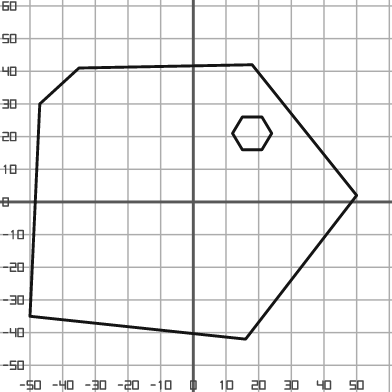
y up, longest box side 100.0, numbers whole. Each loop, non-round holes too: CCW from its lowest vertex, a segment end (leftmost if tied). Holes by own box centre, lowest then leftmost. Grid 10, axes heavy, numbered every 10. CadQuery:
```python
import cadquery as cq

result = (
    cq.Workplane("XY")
    .moveTo(16.0, -42.0)
    .lineTo(50.0, 2.0)
    .lineTo(18.0, 42.0)
    .lineTo(-35.0, 41.0)
    .lineTo(-47.0, 30.0)
    .lineTo(-50.0, -35.0)
    .close()
    .moveTo(15.0, 16.0)
    .lineTo(21.0, 16.0)
    .lineTo(24.0, 21.0)
    .lineTo(21.0, 26.0)
    .lineTo(15.0, 26.0)
    .lineTo(12.0, 21.0)
    .close()
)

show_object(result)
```